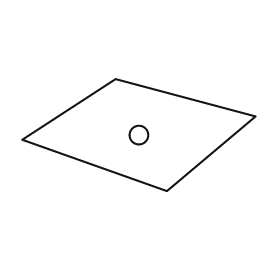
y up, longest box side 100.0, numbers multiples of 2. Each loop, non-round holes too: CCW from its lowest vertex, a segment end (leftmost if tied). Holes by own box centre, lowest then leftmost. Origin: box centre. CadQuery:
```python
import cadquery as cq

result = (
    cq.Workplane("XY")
    .moveTo(12.0, -24.0)
    .lineTo(50.0, 8.0)
    .lineTo(-10.0, 24.0)
    .lineTo(-50.0, -2.0)
    .close()
    .moveTo(0.0, 0.0)
    .circle(4.0)
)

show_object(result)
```